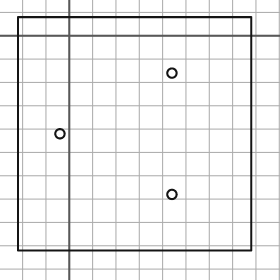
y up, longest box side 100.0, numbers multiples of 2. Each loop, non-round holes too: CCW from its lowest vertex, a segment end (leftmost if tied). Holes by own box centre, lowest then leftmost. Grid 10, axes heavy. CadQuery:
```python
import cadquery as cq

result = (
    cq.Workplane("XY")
    .moveTo(-22.0, -92.0)
    .lineTo(78.0, -92.0)
    .lineTo(78.0, 8.0)
    .lineTo(-22.0, 8.0)
    .close()
    .moveTo(44.0, -68.0)
    .circle(2.0)
    .moveTo(-4.0, -42.0)
    .circle(2.0)
    .moveTo(44.0, -16.0)
    .circle(2.0)
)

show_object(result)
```